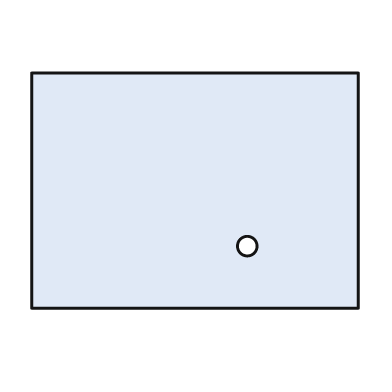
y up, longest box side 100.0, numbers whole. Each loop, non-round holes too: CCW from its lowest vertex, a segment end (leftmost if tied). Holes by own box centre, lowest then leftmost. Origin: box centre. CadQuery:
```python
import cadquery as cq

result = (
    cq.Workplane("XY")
    .moveTo(-50.0, -36.0)
    .lineTo(50.0, -36.0)
    .lineTo(50.0, 36.0)
    .lineTo(-50.0, 36.0)
    .close()
    .moveTo(16.0, -17.0)
    .circle(3.0)
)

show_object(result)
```